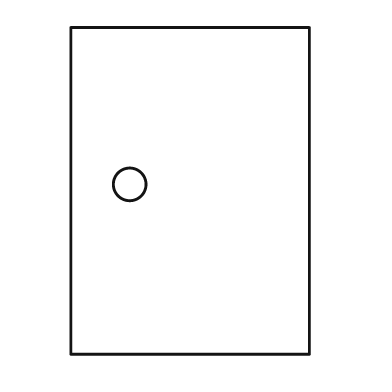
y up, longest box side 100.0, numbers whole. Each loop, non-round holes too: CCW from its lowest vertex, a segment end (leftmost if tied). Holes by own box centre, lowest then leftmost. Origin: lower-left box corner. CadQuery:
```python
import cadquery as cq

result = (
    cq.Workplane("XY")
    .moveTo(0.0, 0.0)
    .lineTo(73.0, 0.0)
    .lineTo(73.0, 100.0)
    .lineTo(0.0, 100.0)
    .close()
    .moveTo(18.0, 52.0)
    .circle(5.0)
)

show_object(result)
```